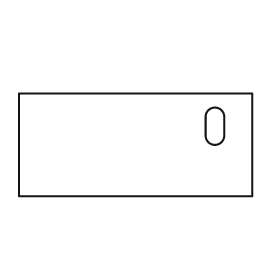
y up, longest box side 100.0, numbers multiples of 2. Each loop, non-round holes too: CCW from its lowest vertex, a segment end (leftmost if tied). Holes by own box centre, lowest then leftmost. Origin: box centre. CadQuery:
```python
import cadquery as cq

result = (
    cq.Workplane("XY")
    .moveTo(-50.0, -22.0)
    .lineTo(50.0, -22.0)
    .lineTo(50.0, 22.0)
    .lineTo(-50.0, 22.0)
    .close()
    .moveTo(30.0, 4.0)
    .threePointArc((34.0, 0.0), (38.0, 4.0))
    .lineTo(38.0, 12.0)
    .threePointArc((34.0, 16.0), (30.0, 12.0))
    .close()
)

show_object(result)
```